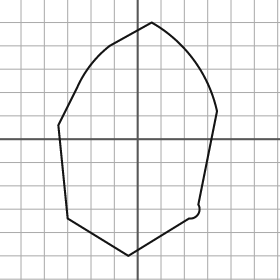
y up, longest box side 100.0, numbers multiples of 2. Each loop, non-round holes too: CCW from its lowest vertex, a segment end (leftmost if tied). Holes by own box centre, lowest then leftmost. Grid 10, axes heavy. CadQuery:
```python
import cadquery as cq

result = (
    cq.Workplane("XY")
    .moveTo(-4.0, -50.0)
    .lineTo(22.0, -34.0)
    .threePointArc((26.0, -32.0), (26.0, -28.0))
    .lineTo(34.0, 12.0)
    .threePointArc((24.0, 34.0), (6.0, 50.0))
    .lineTo(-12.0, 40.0)
    .threePointArc((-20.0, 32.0), (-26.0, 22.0))
    .lineTo(-34.0, 6.0)
    .lineTo(-30.0, -34.0)
    .close()
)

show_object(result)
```